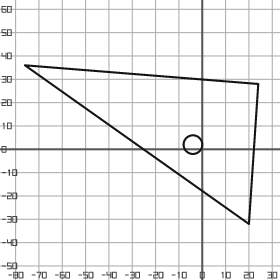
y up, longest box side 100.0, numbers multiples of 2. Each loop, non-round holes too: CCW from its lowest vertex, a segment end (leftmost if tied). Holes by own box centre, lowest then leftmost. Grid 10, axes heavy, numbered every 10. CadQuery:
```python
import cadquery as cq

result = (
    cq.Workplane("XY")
    .moveTo(20.0, -32.0)
    .lineTo(24.0, 28.0)
    .lineTo(-76.0, 36.0)
    .close()
    .moveTo(-4.0, 2.0)
    .circle(4.0)
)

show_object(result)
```